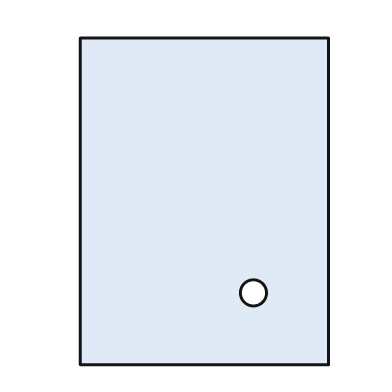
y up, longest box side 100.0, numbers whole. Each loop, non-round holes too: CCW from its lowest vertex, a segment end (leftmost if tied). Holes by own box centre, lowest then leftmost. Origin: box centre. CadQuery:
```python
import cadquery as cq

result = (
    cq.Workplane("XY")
    .moveTo(-38.0, -50.0)
    .lineTo(38.0, -50.0)
    .lineTo(38.0, 50.0)
    .lineTo(-38.0, 50.0)
    .close()
    .moveTo(15.0, -28.0)
    .circle(4.0)
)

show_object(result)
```